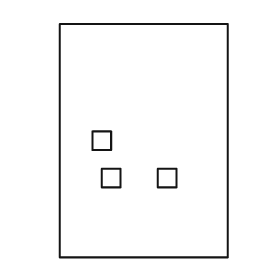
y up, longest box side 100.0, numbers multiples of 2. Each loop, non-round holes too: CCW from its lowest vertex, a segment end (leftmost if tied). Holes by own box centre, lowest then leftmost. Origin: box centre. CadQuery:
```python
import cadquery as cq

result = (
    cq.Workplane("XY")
    .moveTo(-36.0, -50.0)
    .lineTo(36.0, -50.0)
    .lineTo(36.0, 50.0)
    .lineTo(-36.0, 50.0)
    .close()
    .moveTo(-18.0, -20.0)
    .lineTo(-10.0, -20.0)
    .lineTo(-10.0, -12.0)
    .lineTo(-18.0, -12.0)
    .close()
    .moveTo(6.0, -20.0)
    .lineTo(14.0, -20.0)
    .lineTo(14.0, -12.0)
    .lineTo(6.0, -12.0)
    .close()
    .moveTo(-22.0, -4.0)
    .lineTo(-14.0, -4.0)
    .lineTo(-14.0, 4.0)
    .lineTo(-22.0, 4.0)
    .close()
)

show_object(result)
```